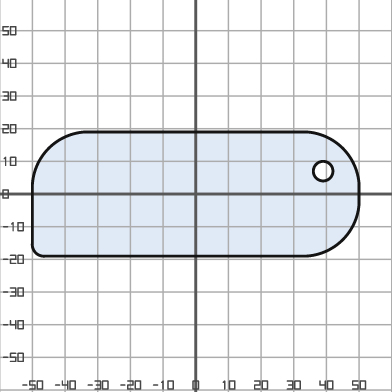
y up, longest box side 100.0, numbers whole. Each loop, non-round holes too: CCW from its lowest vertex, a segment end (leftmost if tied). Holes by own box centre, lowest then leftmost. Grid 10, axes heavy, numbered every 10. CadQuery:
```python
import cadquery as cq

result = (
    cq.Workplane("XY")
    .moveTo(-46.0, -19.0)
    .lineTo(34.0, -19.0)
    .threePointArc((45.0, -14.0), (50.0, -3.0))
    .lineTo(50.0, 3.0)
    .threePointArc((45.0, 14.0), (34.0, 19.0))
    .lineTo(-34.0, 19.0)
    .threePointArc((-45.0, 14.0), (-50.0, 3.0))
    .lineTo(-50.0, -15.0)
    .threePointArc((-49.0, -18.0), (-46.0, -19.0))
    .close()
    .moveTo(39.0, 7.0)
    .circle(3.0)
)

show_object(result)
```